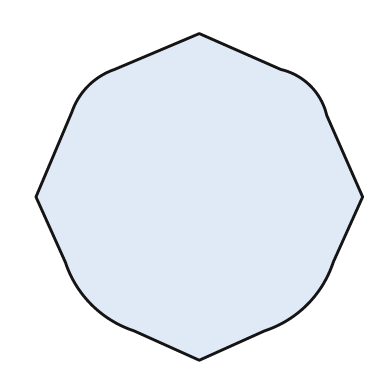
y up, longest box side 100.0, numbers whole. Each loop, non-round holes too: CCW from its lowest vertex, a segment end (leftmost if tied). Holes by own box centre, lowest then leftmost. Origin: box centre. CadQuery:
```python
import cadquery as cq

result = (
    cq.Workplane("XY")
    .moveTo(0.0, -50.0)
    .lineTo(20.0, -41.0)
    .threePointArc((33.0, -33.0), (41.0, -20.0))
    .lineTo(50.0, 0.0)
    .lineTo(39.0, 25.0)
    .threePointArc((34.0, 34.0), (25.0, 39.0))
    .lineTo(0.0, 50.0)
    .lineTo(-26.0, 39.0)
    .threePointArc((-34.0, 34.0), (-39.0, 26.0))
    .lineTo(-50.0, 0.0)
    .lineTo(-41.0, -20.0)
    .threePointArc((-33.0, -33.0), (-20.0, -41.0))
    .close()
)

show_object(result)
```